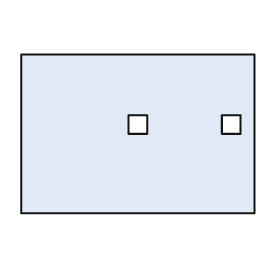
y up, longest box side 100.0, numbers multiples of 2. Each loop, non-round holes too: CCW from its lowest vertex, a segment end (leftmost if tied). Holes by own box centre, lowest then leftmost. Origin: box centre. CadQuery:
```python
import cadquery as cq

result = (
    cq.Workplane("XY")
    .moveTo(-50.0, -34.0)
    .lineTo(50.0, -34.0)
    .lineTo(50.0, 34.0)
    .lineTo(-50.0, 34.0)
    .close()
    .moveTo(-4.0, 0.0)
    .lineTo(4.0, 0.0)
    .lineTo(4.0, 8.0)
    .lineTo(-4.0, 8.0)
    .close()
    .moveTo(36.0, 0.0)
    .lineTo(44.0, 0.0)
    .lineTo(44.0, 8.0)
    .lineTo(36.0, 8.0)
    .close()
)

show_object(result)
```